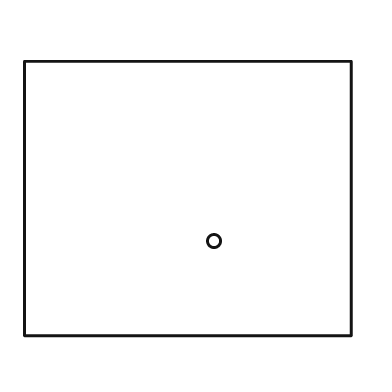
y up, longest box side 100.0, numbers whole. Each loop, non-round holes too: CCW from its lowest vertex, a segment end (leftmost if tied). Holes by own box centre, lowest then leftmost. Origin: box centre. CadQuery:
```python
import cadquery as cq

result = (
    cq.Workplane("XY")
    .moveTo(-50.0, -42.0)
    .lineTo(50.0, -42.0)
    .lineTo(50.0, 42.0)
    .lineTo(-50.0, 42.0)
    .close()
    .moveTo(8.0, -13.0)
    .circle(2.0)
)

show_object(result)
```